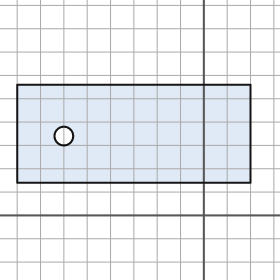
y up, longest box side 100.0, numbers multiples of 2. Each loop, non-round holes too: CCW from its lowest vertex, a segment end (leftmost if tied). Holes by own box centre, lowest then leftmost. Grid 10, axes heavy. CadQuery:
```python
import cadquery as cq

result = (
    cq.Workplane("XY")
    .moveTo(-80.0, 14.0)
    .lineTo(20.0, 14.0)
    .lineTo(20.0, 56.0)
    .lineTo(-80.0, 56.0)
    .close()
    .moveTo(-60.0, 34.0)
    .circle(4.0)
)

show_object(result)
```